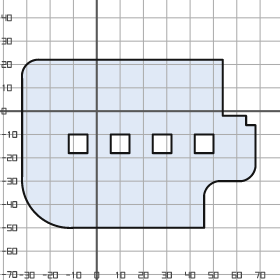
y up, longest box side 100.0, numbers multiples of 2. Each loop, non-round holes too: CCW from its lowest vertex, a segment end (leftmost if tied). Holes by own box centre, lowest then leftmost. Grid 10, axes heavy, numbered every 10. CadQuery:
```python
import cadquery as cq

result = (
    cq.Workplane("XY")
    .moveTo(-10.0, -50.0)
    .lineTo(46.0, -50.0)
    .lineTo(46.0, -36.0)
    .threePointArc((48.0, -32.0), (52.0, -30.0))
    .lineTo(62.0, -30.0)
    .threePointArc((66.0, -28.0), (68.0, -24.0))
    .lineTo(68.0, -6.0)
    .lineTo(64.0, -6.0)
    .lineTo(64.0, -2.0)
    .lineTo(54.0, -2.0)
    .lineTo(54.0, 22.0)
    .lineTo(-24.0, 22.0)
    .threePointArc((-30.0, 20.0), (-32.0, 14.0))
    .lineTo(-32.0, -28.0)
    .threePointArc((-26.0, -44.0), (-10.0, -50.0))
    .close()
    .moveTo(-12.0, -18.0)
    .lineTo(-4.0, -18.0)
    .lineTo(-4.0, -10.0)
    .lineTo(-12.0, -10.0)
    .close()
    .moveTo(6.0, -18.0)
    .lineTo(14.0, -18.0)
    .lineTo(14.0, -10.0)
    .lineTo(6.0, -10.0)
    .close()
    .moveTo(24.0, -18.0)
    .lineTo(32.0, -18.0)
    .lineTo(32.0, -10.0)
    .lineTo(24.0, -10.0)
    .close()
    .moveTo(42.0, -18.0)
    .lineTo(50.0, -18.0)
    .lineTo(50.0, -10.0)
    .lineTo(42.0, -10.0)
    .close()
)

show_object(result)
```